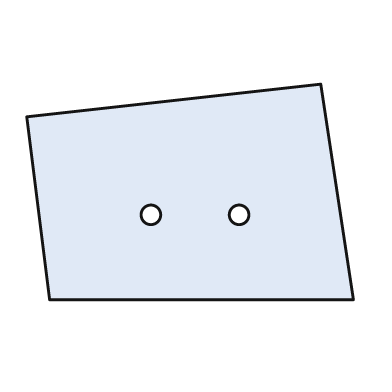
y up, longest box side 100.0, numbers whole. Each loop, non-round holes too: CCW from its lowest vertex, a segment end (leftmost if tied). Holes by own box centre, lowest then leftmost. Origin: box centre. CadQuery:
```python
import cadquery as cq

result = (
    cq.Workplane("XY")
    .moveTo(-43.0, -33.0)
    .lineTo(50.0, -33.0)
    .lineTo(40.0, 33.0)
    .lineTo(-50.0, 23.0)
    .close()
    .moveTo(-12.0, -7.0)
    .circle(3.0)
    .moveTo(15.0, -7.0)
    .circle(3.0)
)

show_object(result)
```